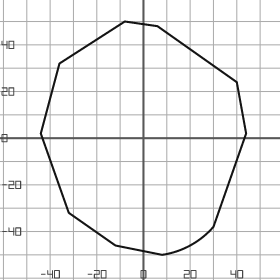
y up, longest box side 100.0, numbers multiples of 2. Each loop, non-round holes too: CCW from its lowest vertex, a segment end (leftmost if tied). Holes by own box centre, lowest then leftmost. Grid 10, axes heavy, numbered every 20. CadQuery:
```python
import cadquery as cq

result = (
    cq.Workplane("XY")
    .moveTo(8.0, -50.0)
    .threePointArc((20.0, -46.0), (30.0, -38.0))
    .lineTo(44.0, 2.0)
    .lineTo(40.0, 24.0)
    .lineTo(6.0, 48.0)
    .lineTo(-8.0, 50.0)
    .lineTo(-36.0, 32.0)
    .lineTo(-44.0, 2.0)
    .lineTo(-32.0, -32.0)
    .lineTo(-12.0, -46.0)
    .close()
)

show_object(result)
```